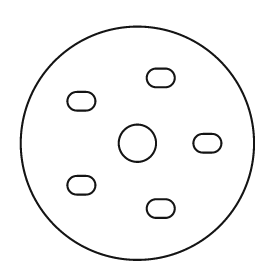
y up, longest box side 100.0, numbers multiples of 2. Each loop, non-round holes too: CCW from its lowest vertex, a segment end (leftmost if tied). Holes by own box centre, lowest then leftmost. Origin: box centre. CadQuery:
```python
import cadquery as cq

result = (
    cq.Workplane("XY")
    .moveTo(0.0, 0.0)
    .circle(50.0)
    .moveTo(8.0, -32.0)
    .lineTo(12.0, -32.0)
    .threePointArc((16.0, -28.0), (12.0, -24.0))
    .lineTo(8.0, -24.0)
    .threePointArc((4.0, -28.0), (8.0, -32.0))
    .close()
    .moveTo(-26.0, -22.0)
    .lineTo(-22.0, -22.0)
    .threePointArc((-18.0, -18.0), (-22.0, -14.0))
    .lineTo(-26.0, -14.0)
    .threePointArc((-30.0, -18.0), (-26.0, -22.0))
    .close()
    .moveTo(0.0, 0.0)
    .circle(8.0)
    .moveTo(28.0, -4.0)
    .lineTo(32.0, -4.0)
    .threePointArc((36.0, 0.0), (32.0, 4.0))
    .lineTo(28.0, 4.0)
    .threePointArc((24.0, 0.0), (28.0, -4.0))
    .close()
    .moveTo(-26.0, 14.0)
    .lineTo(-22.0, 14.0)
    .threePointArc((-18.0, 18.0), (-22.0, 22.0))
    .lineTo(-26.0, 22.0)
    .threePointArc((-30.0, 18.0), (-26.0, 14.0))
    .close()
    .moveTo(8.0, 24.0)
    .lineTo(12.0, 24.0)
    .threePointArc((16.0, 28.0), (12.0, 32.0))
    .lineTo(8.0, 32.0)
    .threePointArc((4.0, 28.0), (8.0, 24.0))
    .close()
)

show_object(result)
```